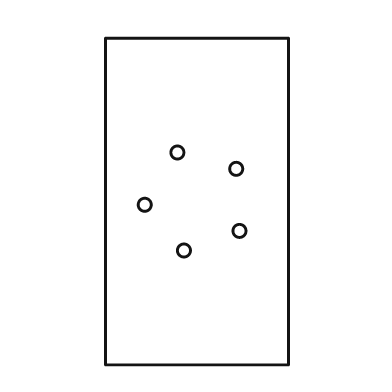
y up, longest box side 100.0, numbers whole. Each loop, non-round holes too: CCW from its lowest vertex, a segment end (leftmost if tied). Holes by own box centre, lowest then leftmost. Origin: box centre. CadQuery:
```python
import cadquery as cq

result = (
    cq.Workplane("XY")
    .moveTo(-28.0, -50.0)
    .lineTo(28.0, -50.0)
    .lineTo(28.0, 50.0)
    .lineTo(-28.0, 50.0)
    .close()
    .moveTo(-4.0, -15.0)
    .circle(2.0)
    .moveTo(13.0, -9.0)
    .circle(2.0)
    .moveTo(-16.0, -1.0)
    .circle(2.0)
    .moveTo(12.0, 10.0)
    .circle(2.0)
    .moveTo(-6.0, 15.0)
    .circle(2.0)
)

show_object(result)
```